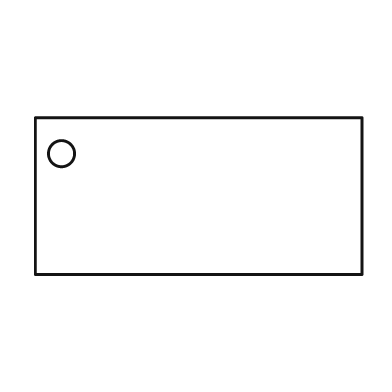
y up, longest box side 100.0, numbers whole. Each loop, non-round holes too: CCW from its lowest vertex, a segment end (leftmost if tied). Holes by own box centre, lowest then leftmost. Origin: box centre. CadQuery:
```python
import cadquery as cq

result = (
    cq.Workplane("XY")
    .moveTo(-50.0, -24.0)
    .lineTo(50.0, -24.0)
    .lineTo(50.0, 24.0)
    .lineTo(-50.0, 24.0)
    .close()
    .moveTo(-42.0, 13.0)
    .circle(4.0)
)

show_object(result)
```